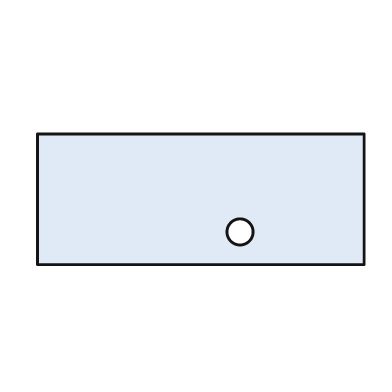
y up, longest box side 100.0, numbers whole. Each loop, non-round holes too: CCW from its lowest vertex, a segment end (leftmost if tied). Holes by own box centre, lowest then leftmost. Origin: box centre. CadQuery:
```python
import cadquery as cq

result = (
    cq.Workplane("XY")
    .moveTo(-50.0, -20.0)
    .lineTo(50.0, -20.0)
    .lineTo(50.0, 20.0)
    .lineTo(-50.0, 20.0)
    .close()
    .moveTo(12.0, -10.0)
    .circle(4.0)
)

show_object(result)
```